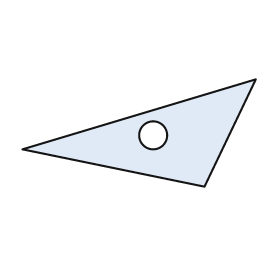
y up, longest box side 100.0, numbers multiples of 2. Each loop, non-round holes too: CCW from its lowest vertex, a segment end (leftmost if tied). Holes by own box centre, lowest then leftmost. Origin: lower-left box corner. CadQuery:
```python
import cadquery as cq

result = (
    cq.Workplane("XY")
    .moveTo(78.0, 0.0)
    .lineTo(100.0, 46.0)
    .lineTo(0.0, 16.0)
    .close()
    .moveTo(56.0, 22.0)
    .circle(6.0)
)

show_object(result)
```